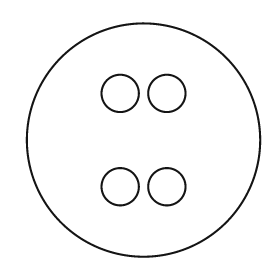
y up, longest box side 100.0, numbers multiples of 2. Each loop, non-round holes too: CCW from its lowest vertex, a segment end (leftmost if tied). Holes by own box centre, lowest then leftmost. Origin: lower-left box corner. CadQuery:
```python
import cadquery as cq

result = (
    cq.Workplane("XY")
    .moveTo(50.0, 50.0)
    .circle(50.0)
    .moveTo(40.0, 30.0)
    .circle(8.0)
    .moveTo(60.0, 30.0)
    .circle(8.0)
    .moveTo(40.0, 70.0)
    .circle(8.0)
    .moveTo(60.0, 70.0)
    .circle(8.0)
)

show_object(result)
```